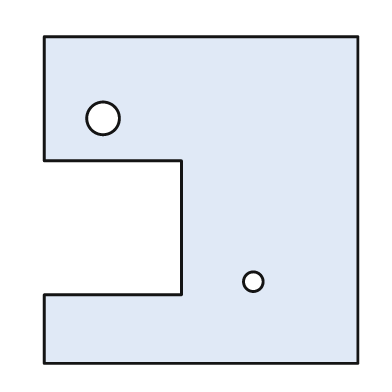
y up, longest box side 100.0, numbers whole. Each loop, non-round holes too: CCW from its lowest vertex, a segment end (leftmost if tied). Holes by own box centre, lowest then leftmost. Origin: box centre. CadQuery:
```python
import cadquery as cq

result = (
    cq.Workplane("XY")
    .moveTo(-48.0, -50.0)
    .lineTo(48.0, -50.0)
    .lineTo(48.0, 50.0)
    .lineTo(-48.0, 50.0)
    .lineTo(-48.0, 12.0)
    .lineTo(-6.0, 12.0)
    .lineTo(-6.0, -29.0)
    .lineTo(-48.0, -29.0)
    .close()
    .moveTo(16.0, -25.0)
    .circle(3.0)
    .moveTo(-30.0, 25.0)
    .circle(5.0)
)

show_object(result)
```